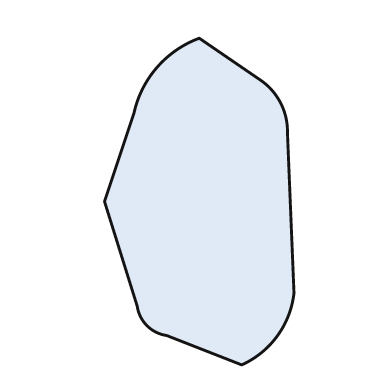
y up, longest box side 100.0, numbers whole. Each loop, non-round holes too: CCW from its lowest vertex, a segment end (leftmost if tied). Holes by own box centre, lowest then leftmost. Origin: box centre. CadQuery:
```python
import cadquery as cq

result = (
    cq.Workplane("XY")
    .moveTo(13.0, -50.0)
    .threePointArc((24.0, -41.0), (29.0, -28.0))
    .lineTo(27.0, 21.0)
    .threePointArc((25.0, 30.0), (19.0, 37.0))
    .lineTo(0.0, 50.0)
    .threePointArc((-13.0, 41.0), (-20.0, 27.0))
    .lineTo(-29.0, 0.0)
    .lineTo(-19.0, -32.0)
    .threePointArc((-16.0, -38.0), (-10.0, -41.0))
    .close()
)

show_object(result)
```